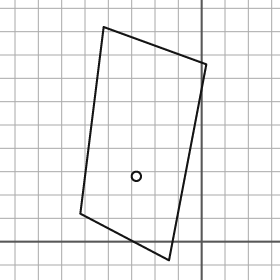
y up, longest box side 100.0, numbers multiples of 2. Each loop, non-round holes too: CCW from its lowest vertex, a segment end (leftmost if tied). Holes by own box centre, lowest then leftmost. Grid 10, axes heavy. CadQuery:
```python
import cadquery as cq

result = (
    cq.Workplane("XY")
    .moveTo(-14.0, -8.0)
    .lineTo(2.0, 76.0)
    .lineTo(-42.0, 92.0)
    .lineTo(-52.0, 12.0)
    .close()
    .moveTo(-28.0, 28.0)
    .circle(2.0)
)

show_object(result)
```